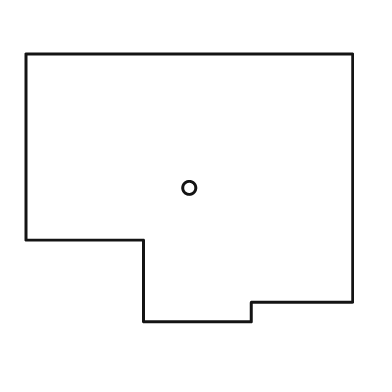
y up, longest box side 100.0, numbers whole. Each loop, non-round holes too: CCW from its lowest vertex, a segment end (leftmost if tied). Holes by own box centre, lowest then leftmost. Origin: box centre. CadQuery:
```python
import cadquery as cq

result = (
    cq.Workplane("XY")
    .moveTo(-14.0, -41.0)
    .lineTo(19.0, -41.0)
    .lineTo(19.0, -35.0)
    .lineTo(50.0, -35.0)
    .lineTo(50.0, 41.0)
    .lineTo(-50.0, 41.0)
    .lineTo(-50.0, -16.0)
    .lineTo(-14.0, -16.0)
    .close()
    .moveTo(0.0, 0.0)
    .circle(2.0)
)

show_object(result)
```